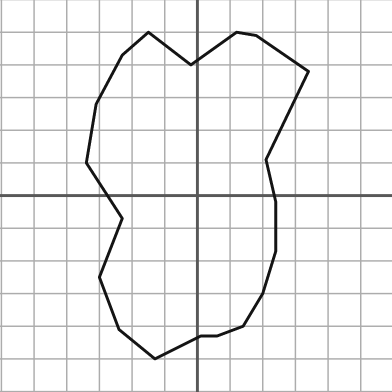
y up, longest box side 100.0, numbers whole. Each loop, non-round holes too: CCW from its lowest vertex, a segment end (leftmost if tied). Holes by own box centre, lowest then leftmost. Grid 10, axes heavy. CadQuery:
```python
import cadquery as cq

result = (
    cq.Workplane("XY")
    .moveTo(-13.0, -50.0)
    .lineTo(1.0, -43.0)
    .lineTo(6.0, -43.0)
    .lineTo(14.0, -40.0)
    .lineTo(20.0, -30.0)
    .lineTo(24.0, -17.0)
    .lineTo(24.0, -2.0)
    .lineTo(21.0, 11.0)
    .lineTo(34.0, 38.0)
    .lineTo(18.0, 49.0)
    .lineTo(12.0, 50.0)
    .lineTo(-2.0, 40.0)
    .lineTo(-15.0, 50.0)
    .lineTo(-23.0, 43.0)
    .lineTo(-31.0, 28.0)
    .lineTo(-34.0, 10.0)
    .lineTo(-23.0, -7.0)
    .lineTo(-30.0, -25.0)
    .lineTo(-24.0, -41.0)
    .close()
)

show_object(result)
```